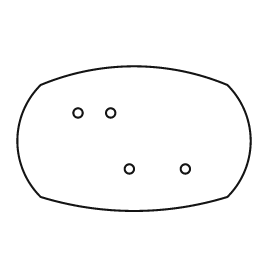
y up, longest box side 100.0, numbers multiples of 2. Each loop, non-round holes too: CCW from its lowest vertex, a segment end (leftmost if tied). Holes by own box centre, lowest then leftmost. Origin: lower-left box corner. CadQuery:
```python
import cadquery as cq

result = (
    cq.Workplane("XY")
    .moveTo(10.0, 6.0)
    .threePointArc((50.0, 0.0), (90.0, 6.0))
    .threePointArc((100.0, 30.0), (90.0, 54.0))
    .threePointArc((50.0, 62.0), (10.0, 54.0))
    .threePointArc((0.0, 30.0), (10.0, 6.0))
    .close()
    .moveTo(48.0, 18.0)
    .circle(2.0)
    .moveTo(72.0, 18.0)
    .circle(2.0)
    .moveTo(26.0, 42.0)
    .circle(2.0)
    .moveTo(40.0, 42.0)
    .circle(2.0)
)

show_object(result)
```